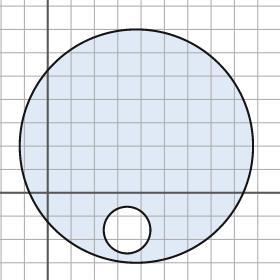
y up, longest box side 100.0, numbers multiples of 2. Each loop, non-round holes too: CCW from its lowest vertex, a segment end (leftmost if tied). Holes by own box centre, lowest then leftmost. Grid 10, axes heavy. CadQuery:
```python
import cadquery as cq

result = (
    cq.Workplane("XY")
    .moveTo(38.0, 20.0)
    .circle(50.0)
    .moveTo(34.0, -16.0)
    .circle(10.0)
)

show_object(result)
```